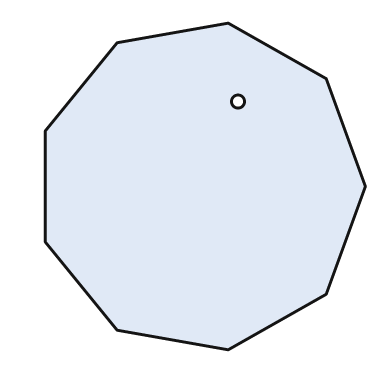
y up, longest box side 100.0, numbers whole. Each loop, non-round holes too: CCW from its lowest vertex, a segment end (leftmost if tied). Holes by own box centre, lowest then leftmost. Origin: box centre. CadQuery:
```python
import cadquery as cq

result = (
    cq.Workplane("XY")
    .moveTo(7.0, -50.0)
    .lineTo(37.0, -33.0)
    .lineTo(49.0, 0.0)
    .lineTo(37.0, 33.0)
    .lineTo(7.0, 50.0)
    .lineTo(-27.0, 44.0)
    .lineTo(-49.0, 17.0)
    .lineTo(-49.0, -17.0)
    .lineTo(-27.0, -44.0)
    .close()
    .moveTo(10.0, 26.0)
    .circle(2.0)
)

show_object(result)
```